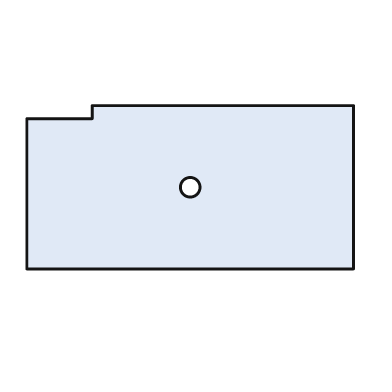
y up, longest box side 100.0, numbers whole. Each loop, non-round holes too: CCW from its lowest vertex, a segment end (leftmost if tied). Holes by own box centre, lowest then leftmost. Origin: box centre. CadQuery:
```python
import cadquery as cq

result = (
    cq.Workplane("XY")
    .moveTo(-50.0, -25.0)
    .lineTo(50.0, -25.0)
    .lineTo(50.0, 25.0)
    .lineTo(-30.0, 25.0)
    .lineTo(-30.0, 21.0)
    .lineTo(-50.0, 21.0)
    .close()
    .moveTo(0.0, 0.0)
    .circle(3.0)
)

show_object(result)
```